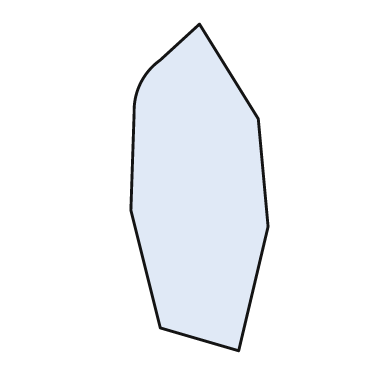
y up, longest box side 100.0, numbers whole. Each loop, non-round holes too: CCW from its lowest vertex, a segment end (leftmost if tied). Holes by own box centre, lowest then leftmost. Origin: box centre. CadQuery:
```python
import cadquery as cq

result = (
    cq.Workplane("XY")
    .moveTo(12.0, -50.0)
    .lineTo(21.0, -12.0)
    .lineTo(18.0, 21.0)
    .lineTo(0.0, 50.0)
    .lineTo(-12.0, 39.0)
    .threePointArc((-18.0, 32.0), (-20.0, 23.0))
    .lineTo(-21.0, -7.0)
    .lineTo(-12.0, -43.0)
    .close()
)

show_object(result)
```